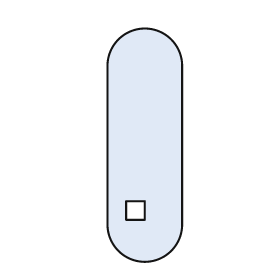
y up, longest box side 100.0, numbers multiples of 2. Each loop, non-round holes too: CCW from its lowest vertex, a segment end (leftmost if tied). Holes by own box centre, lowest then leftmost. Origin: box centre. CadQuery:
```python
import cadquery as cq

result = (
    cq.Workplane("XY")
    .moveTo(-16.0, -34.0)
    .threePointArc((0.0, -50.0), (16.0, -34.0))
    .lineTo(16.0, 34.0)
    .threePointArc((0.0, 50.0), (-16.0, 34.0))
    .close()
    .moveTo(-8.0, -32.0)
    .lineTo(0.0, -32.0)
    .lineTo(0.0, -24.0)
    .lineTo(-8.0, -24.0)
    .close()
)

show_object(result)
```